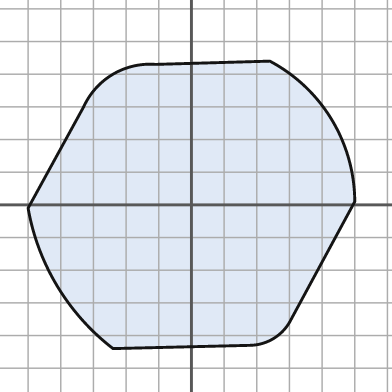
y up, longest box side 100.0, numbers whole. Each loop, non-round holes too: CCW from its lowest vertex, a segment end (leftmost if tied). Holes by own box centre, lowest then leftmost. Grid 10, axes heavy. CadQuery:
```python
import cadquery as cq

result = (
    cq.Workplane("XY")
    .moveTo(-24.0, -44.0)
    .lineTo(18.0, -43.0)
    .threePointArc((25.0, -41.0), (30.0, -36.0))
    .lineTo(50.0, 1.0)
    .threePointArc((43.0, 26.0), (24.0, 44.0))
    .lineTo(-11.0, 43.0)
    .threePointArc((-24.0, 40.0), (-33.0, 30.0))
    .lineTo(-50.0, -1.0)
    .threePointArc((-41.0, -25.0), (-24.0, -44.0))
    .close()
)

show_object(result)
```